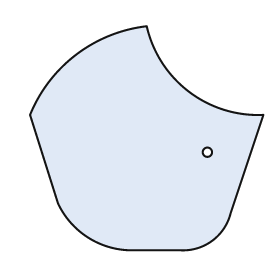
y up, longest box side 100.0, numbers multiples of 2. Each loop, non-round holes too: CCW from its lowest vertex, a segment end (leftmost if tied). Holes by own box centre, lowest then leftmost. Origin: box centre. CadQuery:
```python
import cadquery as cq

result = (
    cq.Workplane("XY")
    .moveTo(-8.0, -48.0)
    .lineTo(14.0, -48.0)
    .threePointArc((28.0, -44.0), (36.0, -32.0))
    .lineTo(50.0, 10.0)
    .threePointArc((18.0, 20.0), (0.0, 48.0))
    .threePointArc((-30.0, 36.0), (-50.0, 10.0))
    .lineTo(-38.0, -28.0)
    .threePointArc((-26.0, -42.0), (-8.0, -48.0))
    .close()
    .moveTo(26.0, -6.0)
    .circle(2.0)
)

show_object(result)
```